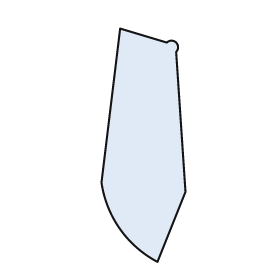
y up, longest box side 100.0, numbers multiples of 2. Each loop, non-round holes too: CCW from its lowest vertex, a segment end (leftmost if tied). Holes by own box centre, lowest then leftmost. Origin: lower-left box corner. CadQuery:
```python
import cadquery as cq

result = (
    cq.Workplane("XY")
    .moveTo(24.0, 0.0)
    .lineTo(36.0, 30.0)
    .lineTo(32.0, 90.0)
    .threePointArc((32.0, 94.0), (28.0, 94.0))
    .lineTo(8.0, 100.0)
    .lineTo(0.0, 34.0)
    .threePointArc((8.0, 14.0), (24.0, 0.0))
    .close()
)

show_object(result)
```